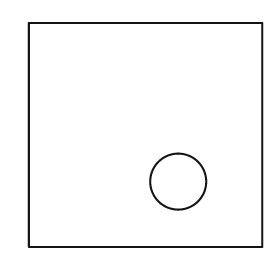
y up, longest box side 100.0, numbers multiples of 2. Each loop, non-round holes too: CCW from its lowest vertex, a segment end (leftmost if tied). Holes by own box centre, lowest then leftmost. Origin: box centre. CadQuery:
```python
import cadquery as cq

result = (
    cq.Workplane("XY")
    .moveTo(-50.0, -48.0)
    .lineTo(50.0, -48.0)
    .lineTo(50.0, 48.0)
    .lineTo(-50.0, 48.0)
    .close()
    .moveTo(14.0, -20.0)
    .circle(12.0)
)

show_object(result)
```